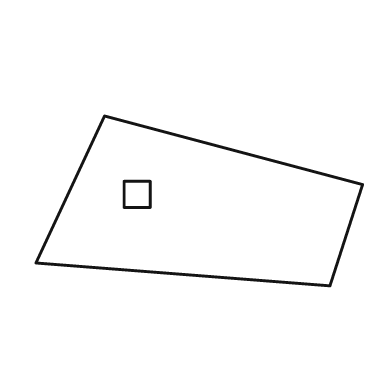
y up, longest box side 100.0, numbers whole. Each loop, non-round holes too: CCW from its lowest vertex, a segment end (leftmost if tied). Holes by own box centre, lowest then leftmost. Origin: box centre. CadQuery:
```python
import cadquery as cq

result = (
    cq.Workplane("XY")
    .moveTo(40.0, -26.0)
    .lineTo(50.0, 5.0)
    .lineTo(-29.0, 26.0)
    .lineTo(-50.0, -19.0)
    .close()
    .moveTo(-23.0, -2.0)
    .lineTo(-15.0, -2.0)
    .lineTo(-15.0, 6.0)
    .lineTo(-23.0, 6.0)
    .close()
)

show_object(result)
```